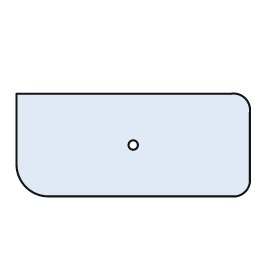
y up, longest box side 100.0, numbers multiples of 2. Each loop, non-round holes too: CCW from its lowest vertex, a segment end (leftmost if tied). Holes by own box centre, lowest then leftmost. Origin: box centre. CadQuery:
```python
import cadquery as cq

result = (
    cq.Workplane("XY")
    .moveTo(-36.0, -22.0)
    .lineTo(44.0, -22.0)
    .threePointArc((48.0, -20.0), (50.0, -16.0))
    .lineTo(50.0, 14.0)
    .threePointArc((48.0, 20.0), (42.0, 22.0))
    .lineTo(-50.0, 22.0)
    .lineTo(-50.0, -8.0)
    .threePointArc((-46.0, -18.0), (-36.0, -22.0))
    .close()
    .moveTo(0.0, 0.0)
    .circle(2.0)
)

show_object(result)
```